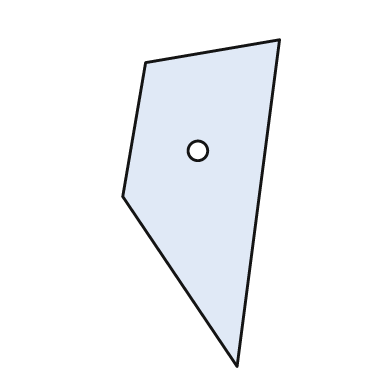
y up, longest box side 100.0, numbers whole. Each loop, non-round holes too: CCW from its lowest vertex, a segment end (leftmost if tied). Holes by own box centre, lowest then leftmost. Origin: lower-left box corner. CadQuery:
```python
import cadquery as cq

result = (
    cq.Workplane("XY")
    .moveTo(35.0, 0.0)
    .lineTo(48.0, 100.0)
    .lineTo(7.0, 93.0)
    .lineTo(0.0, 52.0)
    .close()
    .moveTo(23.0, 66.0)
    .circle(3.0)
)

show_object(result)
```